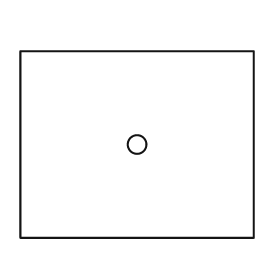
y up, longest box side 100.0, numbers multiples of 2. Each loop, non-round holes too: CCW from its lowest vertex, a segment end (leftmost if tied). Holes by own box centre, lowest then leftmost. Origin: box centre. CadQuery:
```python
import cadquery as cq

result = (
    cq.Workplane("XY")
    .moveTo(-50.0, -40.0)
    .lineTo(50.0, -40.0)
    .lineTo(50.0, 40.0)
    .lineTo(-50.0, 40.0)
    .close()
    .moveTo(0.0, 0.0)
    .circle(4.0)
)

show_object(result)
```